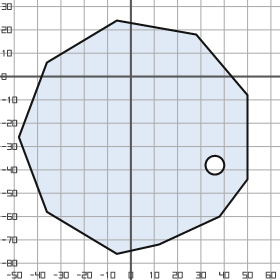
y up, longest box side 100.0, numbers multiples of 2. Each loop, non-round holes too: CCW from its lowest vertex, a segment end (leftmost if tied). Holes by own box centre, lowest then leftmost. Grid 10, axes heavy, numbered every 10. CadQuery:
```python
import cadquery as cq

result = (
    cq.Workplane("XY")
    .moveTo(-6.0, -76.0)
    .lineTo(12.0, -72.0)
    .lineTo(38.0, -60.0)
    .lineTo(50.0, -44.0)
    .lineTo(50.0, -8.0)
    .lineTo(28.0, 18.0)
    .lineTo(-6.0, 24.0)
    .lineTo(-36.0, 6.0)
    .lineTo(-48.0, -26.0)
    .lineTo(-36.0, -58.0)
    .close()
    .moveTo(36.0, -38.0)
    .circle(4.0)
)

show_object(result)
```